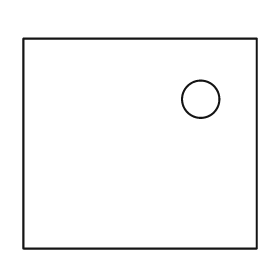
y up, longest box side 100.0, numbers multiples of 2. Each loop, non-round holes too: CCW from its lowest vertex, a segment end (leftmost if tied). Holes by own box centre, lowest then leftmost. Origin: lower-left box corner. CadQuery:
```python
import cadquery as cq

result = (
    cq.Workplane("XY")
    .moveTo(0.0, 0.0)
    .lineTo(100.0, 0.0)
    .lineTo(100.0, 90.0)
    .lineTo(0.0, 90.0)
    .close()
    .moveTo(76.0, 64.0)
    .circle(8.0)
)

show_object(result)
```